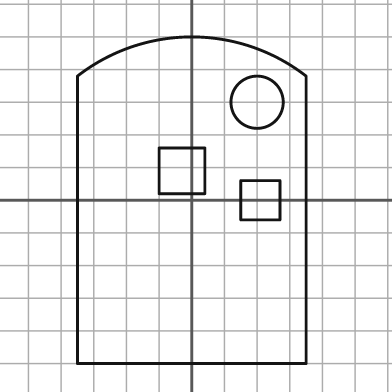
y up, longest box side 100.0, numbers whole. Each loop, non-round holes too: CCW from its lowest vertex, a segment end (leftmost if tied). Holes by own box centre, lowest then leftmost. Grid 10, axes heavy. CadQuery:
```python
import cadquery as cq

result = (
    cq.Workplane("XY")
    .moveTo(-35.0, -50.0)
    .lineTo(35.0, -50.0)
    .lineTo(35.0, 38.0)
    .threePointArc((0.0, 50.0), (-35.0, 38.0))
    .close()
    .moveTo(15.0, -6.0)
    .lineTo(27.0, -6.0)
    .lineTo(27.0, 6.0)
    .lineTo(15.0, 6.0)
    .close()
    .moveTo(-10.0, 2.0)
    .lineTo(4.0, 2.0)
    .lineTo(4.0, 16.0)
    .lineTo(-10.0, 16.0)
    .close()
    .moveTo(20.0, 30.0)
    .circle(8.0)
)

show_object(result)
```